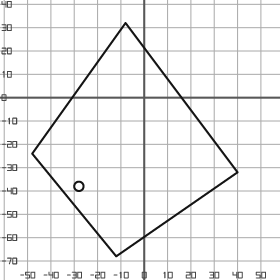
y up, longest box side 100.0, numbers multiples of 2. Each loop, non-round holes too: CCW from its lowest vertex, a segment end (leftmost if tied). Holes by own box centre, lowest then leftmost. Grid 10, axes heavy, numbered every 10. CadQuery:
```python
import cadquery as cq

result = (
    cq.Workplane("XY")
    .moveTo(-12.0, -68.0)
    .lineTo(40.0, -32.0)
    .lineTo(-8.0, 32.0)
    .lineTo(-48.0, -24.0)
    .close()
    .moveTo(-28.0, -38.0)
    .circle(2.0)
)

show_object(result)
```